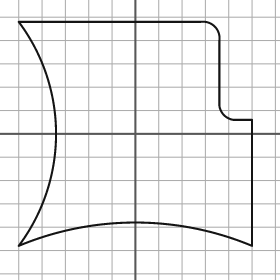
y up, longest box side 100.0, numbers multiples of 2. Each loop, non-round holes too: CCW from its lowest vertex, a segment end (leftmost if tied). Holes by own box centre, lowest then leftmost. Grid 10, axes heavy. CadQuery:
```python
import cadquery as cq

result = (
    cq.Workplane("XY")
    .moveTo(-50.0, -48.0)
    .threePointArc((0.0, -38.0), (50.0, -48.0))
    .lineTo(50.0, 6.0)
    .lineTo(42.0, 6.0)
    .threePointArc((38.0, 8.0), (36.0, 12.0))
    .lineTo(36.0, 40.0)
    .threePointArc((34.0, 46.0), (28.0, 48.0))
    .lineTo(-50.0, 48.0)
    .threePointArc((-34.0, 0.0), (-50.0, -48.0))
    .close()
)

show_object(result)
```